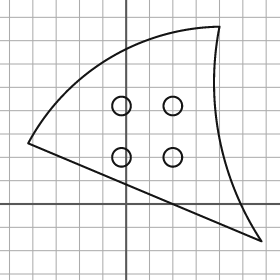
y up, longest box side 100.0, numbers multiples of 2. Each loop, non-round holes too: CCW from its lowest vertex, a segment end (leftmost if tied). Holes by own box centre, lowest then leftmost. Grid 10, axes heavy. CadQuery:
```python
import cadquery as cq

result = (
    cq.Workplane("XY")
    .moveTo(58.0, -16.0)
    .threePointArc((40.0, 28.0), (40.0, 76.0))
    .threePointArc((-8.0, 62.0), (-42.0, 26.0))
    .close()
    .moveTo(-2.0, 20.0)
    .circle(4.0)
    .moveTo(20.0, 20.0)
    .circle(4.0)
    .moveTo(-2.0, 42.0)
    .circle(4.0)
    .moveTo(20.0, 42.0)
    .circle(4.0)
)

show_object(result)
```